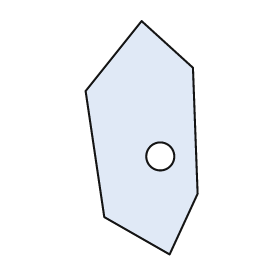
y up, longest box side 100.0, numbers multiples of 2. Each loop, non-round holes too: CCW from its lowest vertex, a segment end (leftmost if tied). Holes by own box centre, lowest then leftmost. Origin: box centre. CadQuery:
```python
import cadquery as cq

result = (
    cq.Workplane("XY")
    .moveTo(12.0, -50.0)
    .lineTo(24.0, -24.0)
    .lineTo(22.0, 30.0)
    .lineTo(0.0, 50.0)
    .lineTo(-24.0, 20.0)
    .lineTo(-16.0, -34.0)
    .close()
    .moveTo(8.0, -8.0)
    .circle(6.0)
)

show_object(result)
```